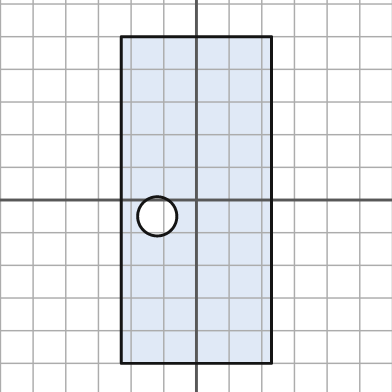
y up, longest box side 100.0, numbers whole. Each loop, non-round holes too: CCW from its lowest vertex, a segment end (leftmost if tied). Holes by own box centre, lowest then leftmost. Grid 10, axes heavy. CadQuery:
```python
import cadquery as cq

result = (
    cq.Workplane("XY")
    .moveTo(-23.0, -50.0)
    .lineTo(23.0, -50.0)
    .lineTo(23.0, 50.0)
    .lineTo(-23.0, 50.0)
    .close()
    .moveTo(-12.0, -5.0)
    .circle(6.0)
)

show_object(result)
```